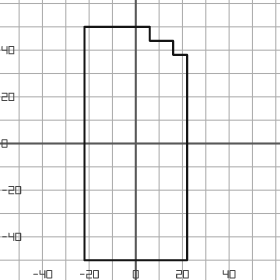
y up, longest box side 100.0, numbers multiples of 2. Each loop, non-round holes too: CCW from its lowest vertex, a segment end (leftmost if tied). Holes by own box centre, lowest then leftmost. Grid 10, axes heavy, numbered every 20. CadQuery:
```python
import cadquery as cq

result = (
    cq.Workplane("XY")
    .moveTo(-22.0, -50.0)
    .lineTo(22.0, -50.0)
    .lineTo(22.0, 38.0)
    .lineTo(16.0, 38.0)
    .lineTo(16.0, 44.0)
    .lineTo(6.0, 44.0)
    .lineTo(6.0, 50.0)
    .lineTo(-22.0, 50.0)
    .close()
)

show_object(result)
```